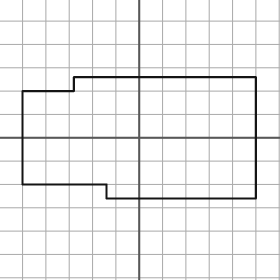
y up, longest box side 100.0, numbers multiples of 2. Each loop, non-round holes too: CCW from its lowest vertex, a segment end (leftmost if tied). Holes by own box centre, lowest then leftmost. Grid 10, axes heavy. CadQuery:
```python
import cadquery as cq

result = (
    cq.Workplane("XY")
    .moveTo(-14.0, -26.0)
    .lineTo(50.0, -26.0)
    .lineTo(50.0, 26.0)
    .lineTo(-28.0, 26.0)
    .lineTo(-28.0, 20.0)
    .lineTo(-50.0, 20.0)
    .lineTo(-50.0, -20.0)
    .lineTo(-14.0, -20.0)
    .close()
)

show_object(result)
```